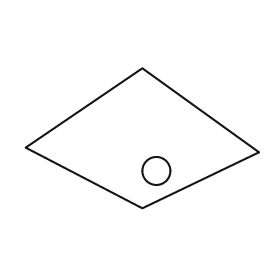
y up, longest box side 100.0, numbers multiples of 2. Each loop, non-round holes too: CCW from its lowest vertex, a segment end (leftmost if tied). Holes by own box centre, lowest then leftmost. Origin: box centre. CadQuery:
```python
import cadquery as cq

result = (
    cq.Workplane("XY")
    .moveTo(0.0, -30.0)
    .lineTo(50.0, -6.0)
    .lineTo(0.0, 30.0)
    .lineTo(-50.0, -4.0)
    .close()
    .moveTo(6.0, -14.0)
    .circle(6.0)
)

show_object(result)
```